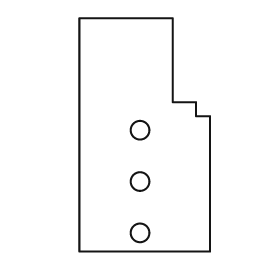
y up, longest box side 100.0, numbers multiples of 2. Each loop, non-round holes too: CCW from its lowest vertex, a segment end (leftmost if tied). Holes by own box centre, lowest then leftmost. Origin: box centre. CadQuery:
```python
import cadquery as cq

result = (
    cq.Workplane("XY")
    .moveTo(-28.0, -50.0)
    .lineTo(28.0, -50.0)
    .lineTo(28.0, 8.0)
    .lineTo(22.0, 8.0)
    .lineTo(22.0, 14.0)
    .lineTo(12.0, 14.0)
    .lineTo(12.0, 50.0)
    .lineTo(-28.0, 50.0)
    .close()
    .moveTo(-2.0, -42.0)
    .circle(4.0)
    .moveTo(-2.0, -20.0)
    .circle(4.0)
    .moveTo(-2.0, 2.0)
    .circle(4.0)
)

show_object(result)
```